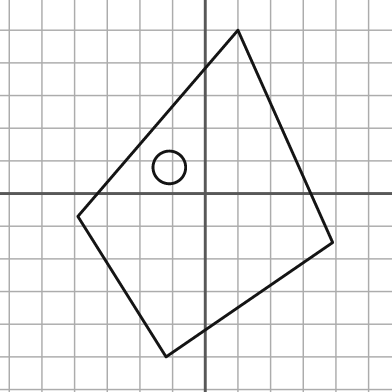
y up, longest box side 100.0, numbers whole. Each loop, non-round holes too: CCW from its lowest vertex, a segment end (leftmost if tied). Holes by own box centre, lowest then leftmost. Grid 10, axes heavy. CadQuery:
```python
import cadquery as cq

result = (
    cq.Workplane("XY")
    .moveTo(-12.0, -50.0)
    .lineTo(39.0, -15.0)
    .lineTo(10.0, 50.0)
    .lineTo(-39.0, -7.0)
    .close()
    .moveTo(-11.0, 8.0)
    .circle(5.0)
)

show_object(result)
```